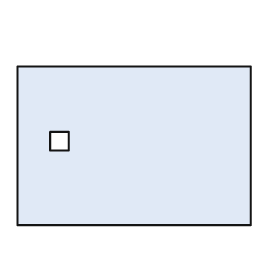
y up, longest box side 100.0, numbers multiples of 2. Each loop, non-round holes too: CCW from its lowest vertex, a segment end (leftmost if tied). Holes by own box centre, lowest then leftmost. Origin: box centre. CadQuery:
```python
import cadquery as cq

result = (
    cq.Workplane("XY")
    .moveTo(-50.0, -34.0)
    .lineTo(50.0, -34.0)
    .lineTo(50.0, 34.0)
    .lineTo(-50.0, 34.0)
    .close()
    .moveTo(-36.0, -2.0)
    .lineTo(-28.0, -2.0)
    .lineTo(-28.0, 6.0)
    .lineTo(-36.0, 6.0)
    .close()
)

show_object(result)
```